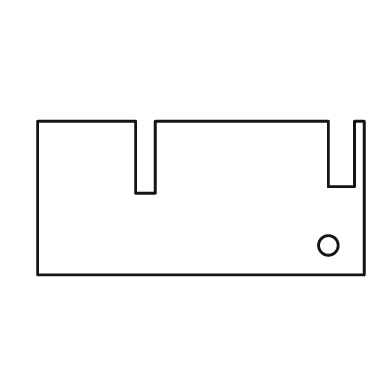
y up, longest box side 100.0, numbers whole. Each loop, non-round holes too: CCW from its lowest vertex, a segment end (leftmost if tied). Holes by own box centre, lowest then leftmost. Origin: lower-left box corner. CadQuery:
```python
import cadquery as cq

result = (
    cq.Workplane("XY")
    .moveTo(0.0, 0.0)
    .lineTo(100.0, 0.0)
    .lineTo(100.0, 47.0)
    .lineTo(97.0, 47.0)
    .lineTo(97.0, 27.0)
    .lineTo(89.0, 27.0)
    .lineTo(89.0, 47.0)
    .lineTo(36.0, 47.0)
    .lineTo(36.0, 25.0)
    .lineTo(30.0, 25.0)
    .lineTo(30.0, 47.0)
    .lineTo(0.0, 47.0)
    .close()
    .moveTo(89.0, 9.0)
    .circle(3.0)
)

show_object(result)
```